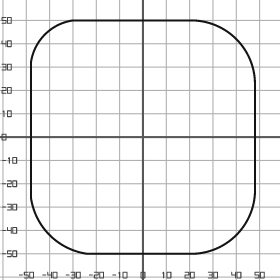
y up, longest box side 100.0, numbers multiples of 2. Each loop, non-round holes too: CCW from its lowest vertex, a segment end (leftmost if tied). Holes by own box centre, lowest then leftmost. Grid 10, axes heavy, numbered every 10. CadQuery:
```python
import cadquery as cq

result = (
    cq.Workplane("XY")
    .moveTo(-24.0, -50.0)
    .lineTo(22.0, -50.0)
    .threePointArc((40.0, -42.0), (48.0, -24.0))
    .lineTo(48.0, 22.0)
    .threePointArc((40.0, 42.0), (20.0, 50.0))
    .lineTo(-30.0, 50.0)
    .threePointArc((-42.0, 44.0), (-48.0, 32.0))
    .lineTo(-48.0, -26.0)
    .threePointArc((-40.0, -42.0), (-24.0, -50.0))
    .close()
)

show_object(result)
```